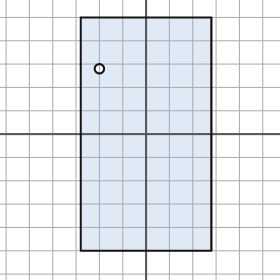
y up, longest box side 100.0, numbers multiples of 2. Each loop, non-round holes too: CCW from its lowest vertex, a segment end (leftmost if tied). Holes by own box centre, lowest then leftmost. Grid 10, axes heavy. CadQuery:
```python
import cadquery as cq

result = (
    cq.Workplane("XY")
    .moveTo(-28.0, -50.0)
    .lineTo(28.0, -50.0)
    .lineTo(28.0, 50.0)
    .lineTo(-28.0, 50.0)
    .close()
    .moveTo(-20.0, 28.0)
    .circle(2.0)
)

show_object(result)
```